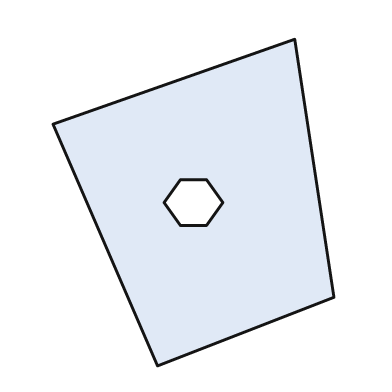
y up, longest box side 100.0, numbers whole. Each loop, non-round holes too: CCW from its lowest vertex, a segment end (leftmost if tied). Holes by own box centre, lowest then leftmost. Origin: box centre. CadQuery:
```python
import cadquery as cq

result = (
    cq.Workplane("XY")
    .moveTo(-11.0, -50.0)
    .lineTo(43.0, -29.0)
    .lineTo(31.0, 50.0)
    .lineTo(-43.0, 24.0)
    .close()
    .moveTo(-4.0, -7.0)
    .lineTo(4.0, -7.0)
    .lineTo(9.0, 0.0)
    .lineTo(4.0, 7.0)
    .lineTo(-4.0, 7.0)
    .lineTo(-9.0, 0.0)
    .close()
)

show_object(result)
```